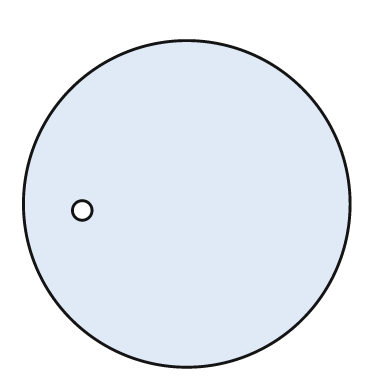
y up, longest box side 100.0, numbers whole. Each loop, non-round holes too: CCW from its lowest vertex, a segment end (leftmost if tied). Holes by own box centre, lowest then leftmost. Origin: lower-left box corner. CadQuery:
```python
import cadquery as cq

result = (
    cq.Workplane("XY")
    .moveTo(50.0, 50.0)
    .circle(50.0)
    .moveTo(18.0, 48.0)
    .circle(3.0)
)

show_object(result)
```